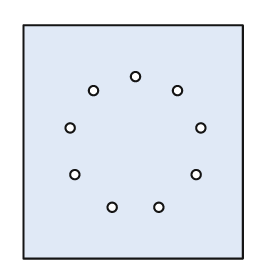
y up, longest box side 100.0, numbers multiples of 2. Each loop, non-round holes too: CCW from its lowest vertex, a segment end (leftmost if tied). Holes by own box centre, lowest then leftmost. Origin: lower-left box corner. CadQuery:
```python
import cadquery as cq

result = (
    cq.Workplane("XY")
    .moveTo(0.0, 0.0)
    .lineTo(94.0, 0.0)
    .lineTo(94.0, 100.0)
    .lineTo(0.0, 100.0)
    .close()
    .moveTo(38.0, 22.0)
    .circle(2.0)
    .moveTo(58.0, 22.0)
    .circle(2.0)
    .moveTo(22.0, 36.0)
    .circle(2.0)
    .moveTo(74.0, 36.0)
    .circle(2.0)
    .moveTo(20.0, 56.0)
    .circle(2.0)
    .moveTo(76.0, 56.0)
    .circle(2.0)
    .moveTo(30.0, 72.0)
    .circle(2.0)
    .moveTo(66.0, 72.0)
    .circle(2.0)
    .moveTo(48.0, 78.0)
    .circle(2.0)
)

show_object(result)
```